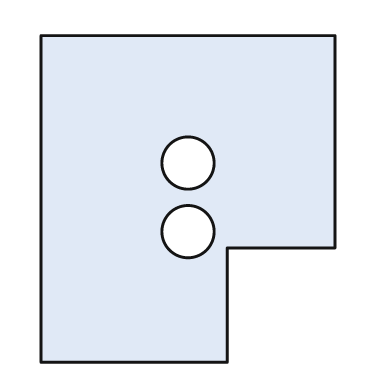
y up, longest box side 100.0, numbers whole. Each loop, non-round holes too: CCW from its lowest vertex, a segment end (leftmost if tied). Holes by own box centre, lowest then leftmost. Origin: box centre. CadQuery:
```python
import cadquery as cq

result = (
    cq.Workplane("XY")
    .moveTo(-45.0, -50.0)
    .lineTo(12.0, -50.0)
    .lineTo(12.0, -15.0)
    .lineTo(45.0, -15.0)
    .lineTo(45.0, 50.0)
    .lineTo(-45.0, 50.0)
    .close()
    .moveTo(0.0, -10.0)
    .circle(8.0)
    .moveTo(0.0, 11.0)
    .circle(8.0)
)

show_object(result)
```